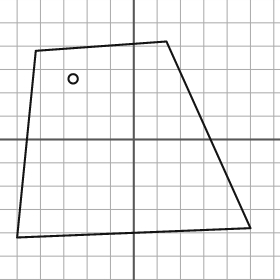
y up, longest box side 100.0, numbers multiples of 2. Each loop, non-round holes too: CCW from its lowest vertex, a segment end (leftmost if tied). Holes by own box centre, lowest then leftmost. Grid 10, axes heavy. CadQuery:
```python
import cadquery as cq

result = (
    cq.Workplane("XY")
    .moveTo(-50.0, -42.0)
    .lineTo(50.0, -38.0)
    .lineTo(14.0, 42.0)
    .lineTo(-42.0, 38.0)
    .close()
    .moveTo(-26.0, 26.0)
    .circle(2.0)
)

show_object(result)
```